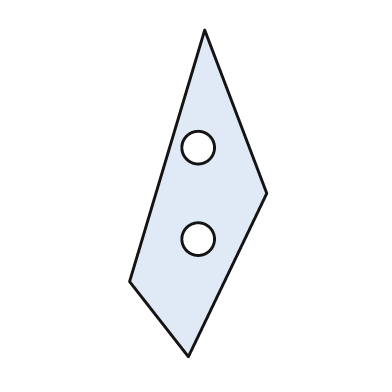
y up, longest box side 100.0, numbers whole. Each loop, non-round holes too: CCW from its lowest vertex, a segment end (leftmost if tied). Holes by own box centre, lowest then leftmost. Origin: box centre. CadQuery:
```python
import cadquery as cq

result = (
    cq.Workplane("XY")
    .moveTo(-3.0, -50.0)
    .lineTo(21.0, 0.0)
    .lineTo(2.0, 50.0)
    .lineTo(-21.0, -27.0)
    .close()
    .moveTo(0.0, -14.0)
    .circle(5.0)
    .moveTo(0.0, 14.0)
    .circle(5.0)
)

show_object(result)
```